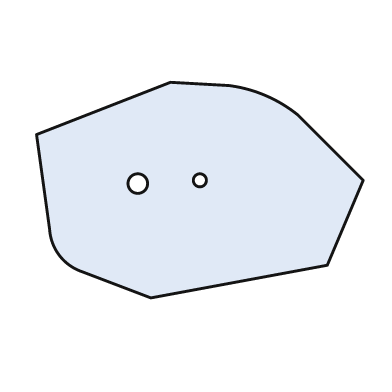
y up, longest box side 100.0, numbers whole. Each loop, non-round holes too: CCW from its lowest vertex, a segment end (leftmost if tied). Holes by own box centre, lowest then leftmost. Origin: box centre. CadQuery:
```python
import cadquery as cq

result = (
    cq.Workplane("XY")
    .moveTo(-15.0, -33.0)
    .lineTo(39.0, -23.0)
    .lineTo(50.0, 3.0)
    .lineTo(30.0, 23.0)
    .threePointArc((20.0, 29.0), (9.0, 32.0))
    .lineTo(-9.0, 33.0)
    .lineTo(-50.0, 17.0)
    .lineTo(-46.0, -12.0)
    .threePointArc((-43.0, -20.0), (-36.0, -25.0))
    .close()
    .moveTo(-19.0, 2.0)
    .circle(3.0)
    .moveTo(0.0, 3.0)
    .circle(2.0)
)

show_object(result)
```